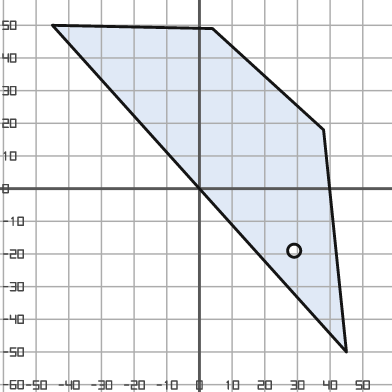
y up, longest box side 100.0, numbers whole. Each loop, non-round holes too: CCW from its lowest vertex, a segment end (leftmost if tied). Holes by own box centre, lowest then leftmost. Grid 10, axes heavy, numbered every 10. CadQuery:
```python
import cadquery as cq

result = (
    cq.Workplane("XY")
    .moveTo(45.0, -50.0)
    .lineTo(38.0, 18.0)
    .lineTo(4.0, 49.0)
    .lineTo(-45.0, 50.0)
    .close()
    .moveTo(29.0, -19.0)
    .circle(2.0)
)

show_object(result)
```